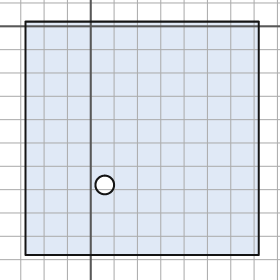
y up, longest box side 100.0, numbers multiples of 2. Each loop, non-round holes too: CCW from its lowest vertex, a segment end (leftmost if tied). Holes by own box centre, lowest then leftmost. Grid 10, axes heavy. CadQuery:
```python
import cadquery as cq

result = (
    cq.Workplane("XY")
    .moveTo(-28.0, -98.0)
    .lineTo(72.0, -98.0)
    .lineTo(72.0, 2.0)
    .lineTo(-28.0, 2.0)
    .close()
    .moveTo(6.0, -68.0)
    .circle(4.0)
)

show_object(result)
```